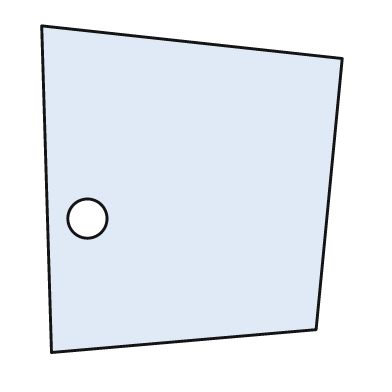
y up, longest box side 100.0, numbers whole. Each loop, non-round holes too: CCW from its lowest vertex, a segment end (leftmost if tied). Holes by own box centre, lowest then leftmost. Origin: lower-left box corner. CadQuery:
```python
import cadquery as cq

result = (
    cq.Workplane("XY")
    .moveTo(3.0, 0.0)
    .lineTo(84.0, 7.0)
    .lineTo(92.0, 90.0)
    .lineTo(0.0, 100.0)
    .close()
    .moveTo(14.0, 41.0)
    .circle(6.0)
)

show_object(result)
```